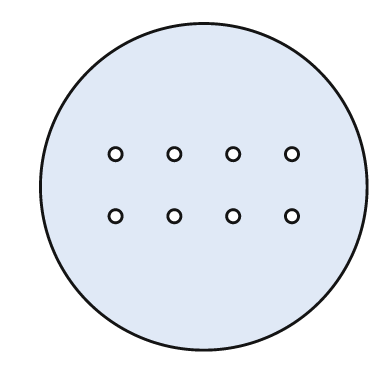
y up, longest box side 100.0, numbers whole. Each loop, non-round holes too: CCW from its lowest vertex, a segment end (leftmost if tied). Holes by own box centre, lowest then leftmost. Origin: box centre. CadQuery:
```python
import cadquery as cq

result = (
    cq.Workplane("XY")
    .moveTo(0.0, 0.0)
    .circle(50.0)
    .moveTo(-27.0, -9.0)
    .circle(2.0)
    .moveTo(-9.0, -9.0)
    .circle(2.0)
    .moveTo(9.0, -9.0)
    .circle(2.0)
    .moveTo(27.0, -9.0)
    .circle(2.0)
    .moveTo(-27.0, 10.0)
    .circle(2.0)
    .moveTo(-9.0, 10.0)
    .circle(2.0)
    .moveTo(9.0, 10.0)
    .circle(2.0)
    .moveTo(27.0, 10.0)
    .circle(2.0)
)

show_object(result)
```